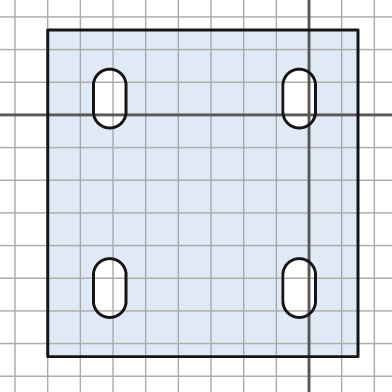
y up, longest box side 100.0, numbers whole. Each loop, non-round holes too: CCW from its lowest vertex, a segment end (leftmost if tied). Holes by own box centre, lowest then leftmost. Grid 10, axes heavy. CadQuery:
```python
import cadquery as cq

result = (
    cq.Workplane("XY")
    .moveTo(-80.0, -74.0)
    .lineTo(15.0, -74.0)
    .lineTo(15.0, 26.0)
    .lineTo(-80.0, 26.0)
    .close()
    .moveTo(-66.0, -57.0)
    .threePointArc((-61.0, -62.0), (-56.0, -57.0))
    .lineTo(-56.0, -49.0)
    .threePointArc((-61.0, -44.0), (-66.0, -49.0))
    .close()
    .moveTo(-8.0, -57.0)
    .threePointArc((-3.0, -62.0), (2.0, -57.0))
    .lineTo(2.0, -49.0)
    .threePointArc((-3.0, -44.0), (-8.0, -49.0))
    .close()
    .moveTo(-66.0, 1.0)
    .threePointArc((-61.0, -4.0), (-56.0, 1.0))
    .lineTo(-56.0, 9.0)
    .threePointArc((-61.0, 14.0), (-66.0, 9.0))
    .close()
    .moveTo(-8.0, 1.0)
    .threePointArc((-3.0, -4.0), (2.0, 1.0))
    .lineTo(2.0, 9.0)
    .threePointArc((-3.0, 14.0), (-8.0, 9.0))
    .close()
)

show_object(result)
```